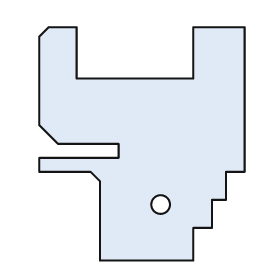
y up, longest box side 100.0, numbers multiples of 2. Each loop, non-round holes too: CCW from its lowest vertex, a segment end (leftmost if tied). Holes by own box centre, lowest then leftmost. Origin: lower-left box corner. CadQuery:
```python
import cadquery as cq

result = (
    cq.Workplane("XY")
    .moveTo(26.0, 0.0)
    .lineTo(66.0, 0.0)
    .lineTo(66.0, 14.0)
    .lineTo(74.0, 14.0)
    .lineTo(74.0, 26.0)
    .lineTo(80.0, 26.0)
    .lineTo(80.0, 38.0)
    .lineTo(88.0, 38.0)
    .lineTo(88.0, 100.0)
    .lineTo(66.0, 100.0)
    .lineTo(66.0, 78.0)
    .lineTo(16.0, 78.0)
    .lineTo(16.0, 100.0)
    .lineTo(4.0, 100.0)
    .lineTo(0.0, 96.0)
    .lineTo(0.0, 58.0)
    .lineTo(8.0, 50.0)
    .lineTo(34.0, 50.0)
    .lineTo(34.0, 44.0)
    .lineTo(0.0, 44.0)
    .lineTo(0.0, 38.0)
    .lineTo(22.0, 38.0)
    .lineTo(26.0, 34.0)
    .close()
    .moveTo(52.0, 24.0)
    .circle(4.0)
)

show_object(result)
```